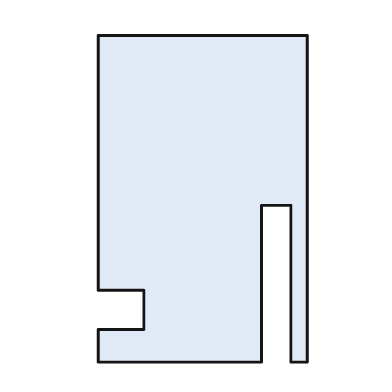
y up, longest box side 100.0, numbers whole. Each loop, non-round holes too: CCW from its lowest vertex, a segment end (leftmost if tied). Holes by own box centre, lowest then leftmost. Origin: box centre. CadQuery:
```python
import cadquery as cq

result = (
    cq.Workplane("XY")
    .moveTo(-32.0, -50.0)
    .lineTo(18.0, -50.0)
    .lineTo(18.0, -2.0)
    .lineTo(27.0, -2.0)
    .lineTo(27.0, -50.0)
    .lineTo(32.0, -50.0)
    .lineTo(32.0, 50.0)
    .lineTo(-32.0, 50.0)
    .lineTo(-32.0, -28.0)
    .lineTo(-18.0, -28.0)
    .lineTo(-18.0, -40.0)
    .lineTo(-32.0, -40.0)
    .close()
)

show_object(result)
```